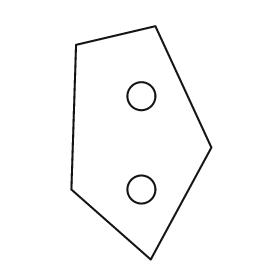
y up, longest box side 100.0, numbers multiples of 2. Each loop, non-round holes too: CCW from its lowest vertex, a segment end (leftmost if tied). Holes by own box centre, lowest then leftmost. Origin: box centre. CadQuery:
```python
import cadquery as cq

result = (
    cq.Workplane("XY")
    .moveTo(4.0, -50.0)
    .lineTo(30.0, -2.0)
    .lineTo(6.0, 50.0)
    .lineTo(-28.0, 42.0)
    .lineTo(-30.0, -20.0)
    .close()
    .moveTo(0.0, -20.0)
    .circle(6.0)
    .moveTo(0.0, 20.0)
    .circle(6.0)
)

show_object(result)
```